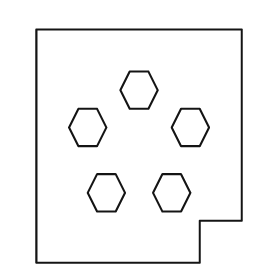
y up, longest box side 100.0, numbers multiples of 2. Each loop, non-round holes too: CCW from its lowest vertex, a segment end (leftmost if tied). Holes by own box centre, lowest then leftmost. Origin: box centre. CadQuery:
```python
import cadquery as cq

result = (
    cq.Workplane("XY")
    .moveTo(-44.0, -50.0)
    .lineTo(26.0, -50.0)
    .lineTo(26.0, -32.0)
    .lineTo(44.0, -32.0)
    .lineTo(44.0, 50.0)
    .lineTo(-44.0, 50.0)
    .close()
    .moveTo(-18.0, -28.0)
    .lineTo(-10.0, -28.0)
    .lineTo(-6.0, -20.0)
    .lineTo(-10.0, -12.0)
    .lineTo(-18.0, -12.0)
    .lineTo(-22.0, -20.0)
    .close()
    .moveTo(10.0, -28.0)
    .lineTo(18.0, -28.0)
    .lineTo(22.0, -20.0)
    .lineTo(18.0, -12.0)
    .lineTo(10.0, -12.0)
    .lineTo(6.0, -20.0)
    .close()
    .moveTo(-26.0, 0.0)
    .lineTo(-18.0, 0.0)
    .lineTo(-14.0, 8.0)
    .lineTo(-18.0, 16.0)
    .lineTo(-26.0, 16.0)
    .lineTo(-30.0, 8.0)
    .close()
    .moveTo(18.0, 0.0)
    .lineTo(26.0, 0.0)
    .lineTo(30.0, 8.0)
    .lineTo(26.0, 16.0)
    .lineTo(18.0, 16.0)
    .lineTo(14.0, 8.0)
    .close()
    .moveTo(-4.0, 16.0)
    .lineTo(4.0, 16.0)
    .lineTo(8.0, 24.0)
    .lineTo(4.0, 32.0)
    .lineTo(-4.0, 32.0)
    .lineTo(-8.0, 24.0)
    .close()
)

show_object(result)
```